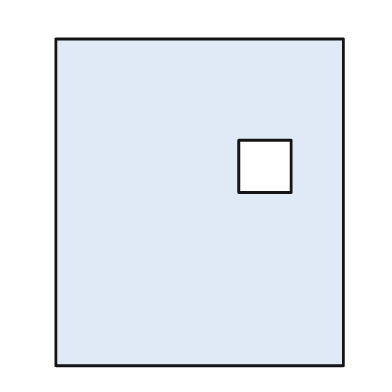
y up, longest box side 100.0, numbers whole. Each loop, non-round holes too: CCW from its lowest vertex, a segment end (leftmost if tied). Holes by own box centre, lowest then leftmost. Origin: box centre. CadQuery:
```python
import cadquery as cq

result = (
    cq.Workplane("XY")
    .moveTo(-44.0, -50.0)
    .lineTo(44.0, -50.0)
    .lineTo(44.0, 50.0)
    .lineTo(-44.0, 50.0)
    .close()
    .moveTo(12.0, 3.0)
    .lineTo(28.0, 3.0)
    .lineTo(28.0, 19.0)
    .lineTo(12.0, 19.0)
    .close()
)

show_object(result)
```